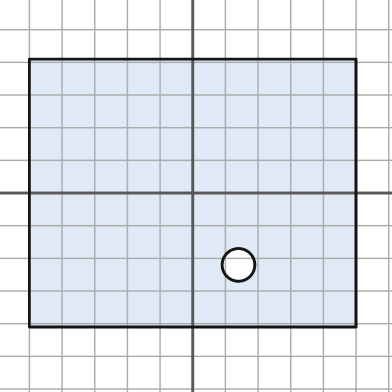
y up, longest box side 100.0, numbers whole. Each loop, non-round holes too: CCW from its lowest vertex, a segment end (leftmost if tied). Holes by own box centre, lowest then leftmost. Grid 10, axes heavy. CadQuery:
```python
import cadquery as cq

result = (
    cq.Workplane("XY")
    .moveTo(-50.0, -41.0)
    .lineTo(50.0, -41.0)
    .lineTo(50.0, 41.0)
    .lineTo(-50.0, 41.0)
    .close()
    .moveTo(14.0, -22.0)
    .circle(5.0)
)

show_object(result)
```